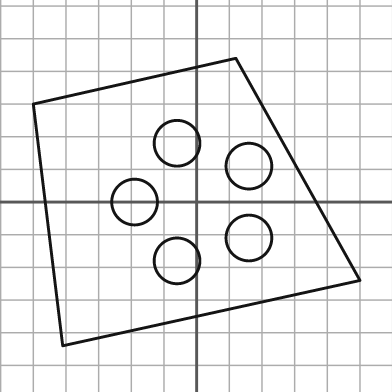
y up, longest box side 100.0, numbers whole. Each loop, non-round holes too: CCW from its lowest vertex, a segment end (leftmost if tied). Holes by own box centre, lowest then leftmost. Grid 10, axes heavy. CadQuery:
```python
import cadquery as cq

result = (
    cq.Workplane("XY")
    .moveTo(-41.0, -44.0)
    .lineTo(50.0, -24.0)
    .lineTo(12.0, 44.0)
    .lineTo(-50.0, 30.0)
    .close()
    .moveTo(-6.0, -18.0)
    .circle(7.0)
    .moveTo(16.0, -11.0)
    .circle(7.0)
    .moveTo(-19.0, 0.0)
    .circle(7.0)
    .moveTo(16.0, 11.0)
    .circle(7.0)
    .moveTo(-6.0, 18.0)
    .circle(7.0)
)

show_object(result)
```